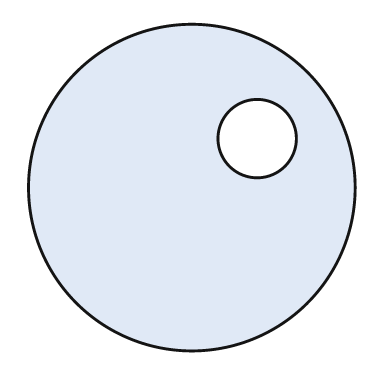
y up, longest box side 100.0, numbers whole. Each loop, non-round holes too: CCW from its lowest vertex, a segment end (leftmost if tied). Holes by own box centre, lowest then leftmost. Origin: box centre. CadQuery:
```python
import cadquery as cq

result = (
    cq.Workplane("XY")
    .moveTo(0.0, 0.0)
    .circle(50.0)
    .moveTo(20.0, 15.0)
    .circle(12.0)
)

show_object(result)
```